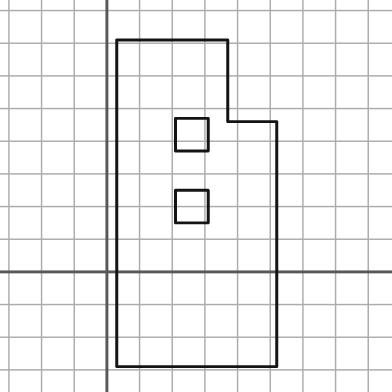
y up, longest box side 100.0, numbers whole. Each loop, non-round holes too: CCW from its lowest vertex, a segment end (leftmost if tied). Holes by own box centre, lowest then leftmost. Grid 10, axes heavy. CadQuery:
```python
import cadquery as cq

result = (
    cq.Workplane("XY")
    .moveTo(3.0, -29.0)
    .lineTo(52.0, -29.0)
    .lineTo(52.0, 46.0)
    .lineTo(37.0, 46.0)
    .lineTo(37.0, 71.0)
    .lineTo(3.0, 71.0)
    .close()
    .moveTo(21.0, 15.0)
    .lineTo(31.0, 15.0)
    .lineTo(31.0, 25.0)
    .lineTo(21.0, 25.0)
    .close()
    .moveTo(21.0, 37.0)
    .lineTo(31.0, 37.0)
    .lineTo(31.0, 47.0)
    .lineTo(21.0, 47.0)
    .close()
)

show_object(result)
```